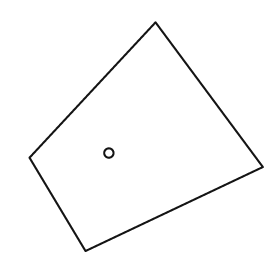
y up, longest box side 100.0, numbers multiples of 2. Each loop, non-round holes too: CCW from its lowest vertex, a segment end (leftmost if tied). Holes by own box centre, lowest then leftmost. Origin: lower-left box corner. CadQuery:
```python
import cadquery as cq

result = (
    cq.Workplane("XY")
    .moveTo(24.0, 0.0)
    .lineTo(100.0, 36.0)
    .lineTo(54.0, 98.0)
    .lineTo(0.0, 40.0)
    .close()
    .moveTo(34.0, 42.0)
    .circle(2.0)
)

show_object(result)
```